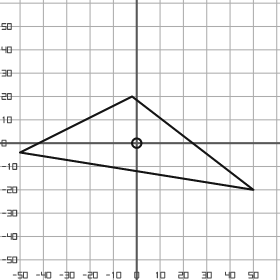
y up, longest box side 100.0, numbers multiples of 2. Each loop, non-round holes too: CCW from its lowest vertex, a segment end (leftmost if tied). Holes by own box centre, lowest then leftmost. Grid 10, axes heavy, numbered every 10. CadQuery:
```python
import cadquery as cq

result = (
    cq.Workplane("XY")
    .moveTo(50.0, -20.0)
    .lineTo(-2.0, 20.0)
    .lineTo(-50.0, -4.0)
    .close()
    .moveTo(0.0, 0.0)
    .circle(2.0)
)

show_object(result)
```